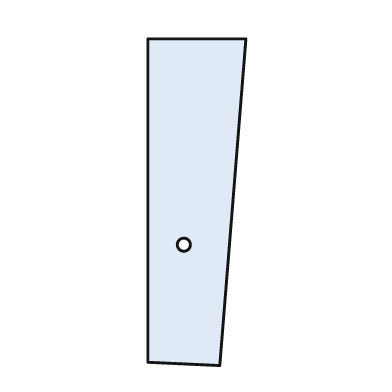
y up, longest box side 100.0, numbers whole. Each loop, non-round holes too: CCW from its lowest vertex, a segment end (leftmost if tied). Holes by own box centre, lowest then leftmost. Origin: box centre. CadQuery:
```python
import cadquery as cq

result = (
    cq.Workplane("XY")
    .moveTo(7.0, -50.0)
    .lineTo(15.0, 50.0)
    .lineTo(-15.0, 50.0)
    .lineTo(-15.0, -49.0)
    .close()
    .moveTo(-4.0, -13.0)
    .circle(2.0)
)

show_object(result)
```